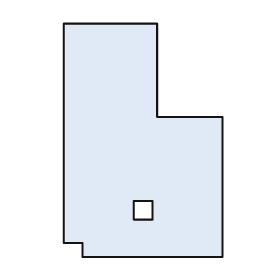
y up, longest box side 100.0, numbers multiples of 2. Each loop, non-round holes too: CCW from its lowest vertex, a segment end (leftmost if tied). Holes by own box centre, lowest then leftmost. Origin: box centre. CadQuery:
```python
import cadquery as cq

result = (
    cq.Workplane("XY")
    .moveTo(-26.0, -50.0)
    .lineTo(34.0, -50.0)
    .lineTo(34.0, 10.0)
    .lineTo(6.0, 10.0)
    .lineTo(6.0, 50.0)
    .lineTo(-34.0, 50.0)
    .lineTo(-34.0, -44.0)
    .lineTo(-26.0, -44.0)
    .close()
    .moveTo(-4.0, -34.0)
    .lineTo(4.0, -34.0)
    .lineTo(4.0, -26.0)
    .lineTo(-4.0, -26.0)
    .close()
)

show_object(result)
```